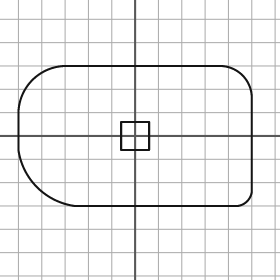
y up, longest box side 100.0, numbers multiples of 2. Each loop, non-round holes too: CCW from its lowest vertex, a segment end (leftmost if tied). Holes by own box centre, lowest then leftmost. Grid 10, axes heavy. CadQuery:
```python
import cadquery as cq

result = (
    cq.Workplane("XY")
    .moveTo(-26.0, -30.0)
    .lineTo(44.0, -30.0)
    .threePointArc((48.0, -28.0), (50.0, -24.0))
    .lineTo(50.0, 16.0)
    .threePointArc((46.0, 26.0), (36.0, 30.0))
    .lineTo(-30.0, 30.0)
    .threePointArc((-44.0, 24.0), (-50.0, 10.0))
    .lineTo(-50.0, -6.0)
    .threePointArc((-42.0, -22.0), (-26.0, -30.0))
    .close()
    .moveTo(-6.0, -6.0)
    .lineTo(6.0, -6.0)
    .lineTo(6.0, 6.0)
    .lineTo(-6.0, 6.0)
    .close()
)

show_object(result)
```